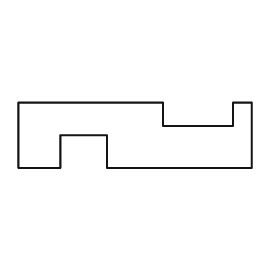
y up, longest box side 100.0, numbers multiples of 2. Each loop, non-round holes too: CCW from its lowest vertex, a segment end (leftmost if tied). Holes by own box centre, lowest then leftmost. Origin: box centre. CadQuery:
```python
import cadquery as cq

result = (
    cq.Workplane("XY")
    .moveTo(-50.0, -14.0)
    .lineTo(-32.0, -14.0)
    .lineTo(-32.0, 0.0)
    .lineTo(-12.0, 0.0)
    .lineTo(-12.0, -14.0)
    .lineTo(50.0, -14.0)
    .lineTo(50.0, 14.0)
    .lineTo(42.0, 14.0)
    .lineTo(42.0, 4.0)
    .lineTo(12.0, 4.0)
    .lineTo(12.0, 14.0)
    .lineTo(-50.0, 14.0)
    .close()
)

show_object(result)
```